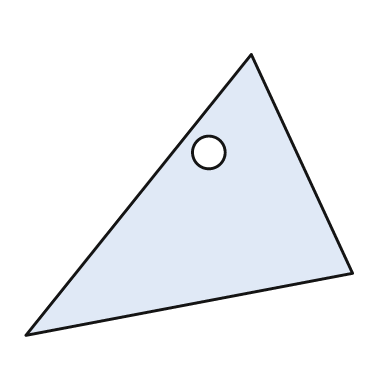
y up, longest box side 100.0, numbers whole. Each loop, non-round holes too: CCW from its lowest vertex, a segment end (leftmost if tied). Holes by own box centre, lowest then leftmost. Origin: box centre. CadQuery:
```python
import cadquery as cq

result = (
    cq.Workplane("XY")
    .moveTo(-50.0, -43.0)
    .lineTo(50.0, -24.0)
    .lineTo(19.0, 43.0)
    .close()
    .moveTo(6.0, 13.0)
    .circle(5.0)
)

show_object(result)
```